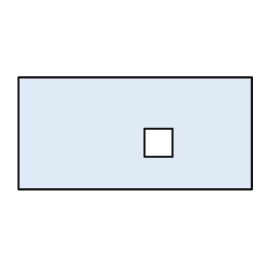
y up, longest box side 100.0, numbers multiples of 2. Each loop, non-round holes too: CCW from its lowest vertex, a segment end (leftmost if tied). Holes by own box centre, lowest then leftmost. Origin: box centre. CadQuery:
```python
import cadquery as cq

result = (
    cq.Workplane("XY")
    .moveTo(-50.0, -24.0)
    .lineTo(50.0, -24.0)
    .lineTo(50.0, 24.0)
    .lineTo(-50.0, 24.0)
    .close()
    .moveTo(4.0, -10.0)
    .lineTo(16.0, -10.0)
    .lineTo(16.0, 2.0)
    .lineTo(4.0, 2.0)
    .close()
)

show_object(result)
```